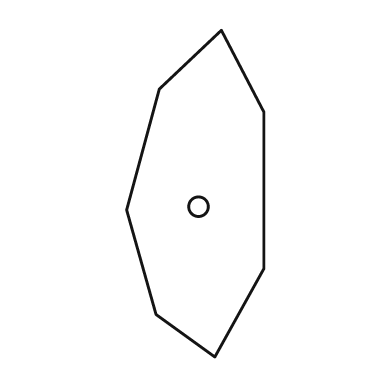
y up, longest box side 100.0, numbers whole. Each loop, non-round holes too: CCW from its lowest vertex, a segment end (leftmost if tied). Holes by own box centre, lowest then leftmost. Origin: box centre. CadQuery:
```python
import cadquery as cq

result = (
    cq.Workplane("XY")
    .moveTo(6.0, -50.0)
    .lineTo(21.0, -23.0)
    .lineTo(21.0, 25.0)
    .lineTo(8.0, 50.0)
    .lineTo(-11.0, 32.0)
    .lineTo(-21.0, -5.0)
    .lineTo(-12.0, -37.0)
    .close()
    .moveTo(1.0, -4.0)
    .circle(3.0)
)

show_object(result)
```